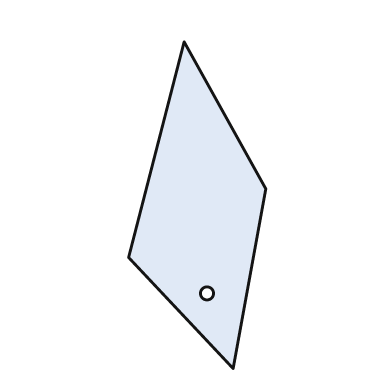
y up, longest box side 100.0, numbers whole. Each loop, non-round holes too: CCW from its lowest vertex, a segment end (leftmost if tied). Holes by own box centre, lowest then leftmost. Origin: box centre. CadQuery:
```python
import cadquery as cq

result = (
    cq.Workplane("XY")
    .moveTo(11.0, -50.0)
    .lineTo(21.0, 5.0)
    .lineTo(-4.0, 50.0)
    .lineTo(-21.0, -16.0)
    .close()
    .moveTo(3.0, -27.0)
    .circle(2.0)
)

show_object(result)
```